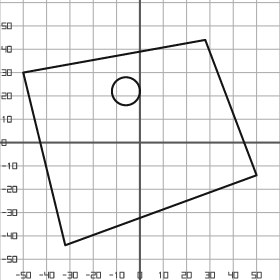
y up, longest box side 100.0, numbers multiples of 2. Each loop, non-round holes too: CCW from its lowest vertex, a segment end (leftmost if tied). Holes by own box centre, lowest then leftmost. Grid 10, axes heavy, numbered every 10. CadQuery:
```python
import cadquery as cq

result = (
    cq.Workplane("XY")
    .moveTo(-32.0, -44.0)
    .lineTo(50.0, -14.0)
    .lineTo(28.0, 44.0)
    .lineTo(-50.0, 30.0)
    .close()
    .moveTo(-6.0, 22.0)
    .circle(6.0)
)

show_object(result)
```